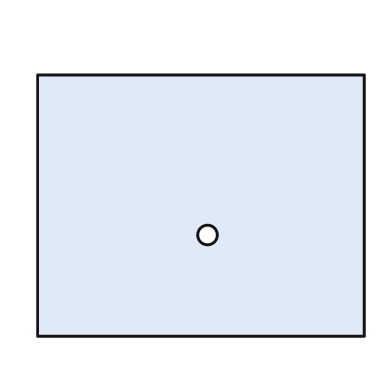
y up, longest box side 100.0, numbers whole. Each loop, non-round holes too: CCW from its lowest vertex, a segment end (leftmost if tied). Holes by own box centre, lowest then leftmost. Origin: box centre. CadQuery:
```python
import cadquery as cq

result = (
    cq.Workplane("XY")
    .moveTo(-50.0, -40.0)
    .lineTo(50.0, -40.0)
    .lineTo(50.0, 40.0)
    .lineTo(-50.0, 40.0)
    .close()
    .moveTo(2.0, -9.0)
    .circle(3.0)
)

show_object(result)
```